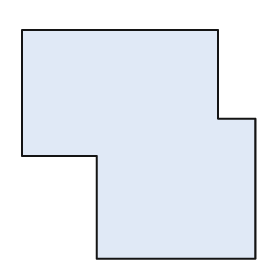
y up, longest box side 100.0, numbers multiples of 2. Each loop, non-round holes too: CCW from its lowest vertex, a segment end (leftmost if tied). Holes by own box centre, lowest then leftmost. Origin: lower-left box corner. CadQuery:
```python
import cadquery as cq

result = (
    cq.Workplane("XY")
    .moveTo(32.0, 0.0)
    .lineTo(100.0, 0.0)
    .lineTo(100.0, 60.0)
    .lineTo(84.0, 60.0)
    .lineTo(84.0, 98.0)
    .lineTo(0.0, 98.0)
    .lineTo(0.0, 44.0)
    .lineTo(32.0, 44.0)
    .close()
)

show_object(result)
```